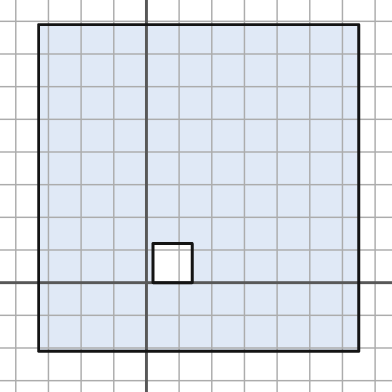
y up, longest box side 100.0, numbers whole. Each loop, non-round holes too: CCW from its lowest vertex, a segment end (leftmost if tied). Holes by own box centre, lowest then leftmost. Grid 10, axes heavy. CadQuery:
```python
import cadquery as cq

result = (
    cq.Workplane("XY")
    .moveTo(-33.0, -21.0)
    .lineTo(65.0, -21.0)
    .lineTo(65.0, 79.0)
    .lineTo(-33.0, 79.0)
    .close()
    .moveTo(2.0, 0.0)
    .lineTo(14.0, 0.0)
    .lineTo(14.0, 12.0)
    .lineTo(2.0, 12.0)
    .close()
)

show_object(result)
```